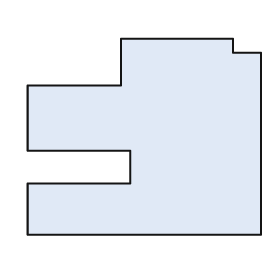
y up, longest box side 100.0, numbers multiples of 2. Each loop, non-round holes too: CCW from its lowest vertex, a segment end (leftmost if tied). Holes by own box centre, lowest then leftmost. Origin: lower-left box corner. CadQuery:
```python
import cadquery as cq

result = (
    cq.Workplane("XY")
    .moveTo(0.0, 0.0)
    .lineTo(100.0, 0.0)
    .lineTo(100.0, 78.0)
    .lineTo(88.0, 78.0)
    .lineTo(88.0, 84.0)
    .lineTo(40.0, 84.0)
    .lineTo(40.0, 64.0)
    .lineTo(0.0, 64.0)
    .lineTo(0.0, 36.0)
    .lineTo(44.0, 36.0)
    .lineTo(44.0, 22.0)
    .lineTo(0.0, 22.0)
    .close()
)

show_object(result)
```